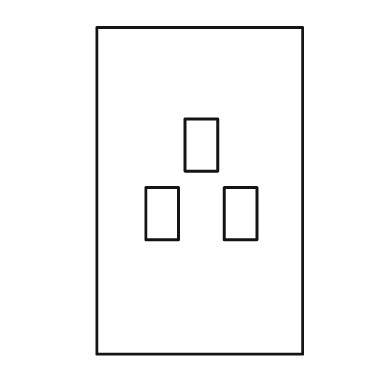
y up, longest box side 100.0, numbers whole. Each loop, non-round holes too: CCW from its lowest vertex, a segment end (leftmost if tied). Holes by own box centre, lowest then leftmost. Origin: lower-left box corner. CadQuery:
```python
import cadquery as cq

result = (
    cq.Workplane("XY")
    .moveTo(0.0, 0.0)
    .lineTo(63.0, 0.0)
    .lineTo(63.0, 100.0)
    .lineTo(0.0, 100.0)
    .close()
    .moveTo(15.0, 35.0)
    .lineTo(25.0, 35.0)
    .lineTo(25.0, 51.0)
    .lineTo(15.0, 51.0)
    .close()
    .moveTo(39.0, 35.0)
    .lineTo(49.0, 35.0)
    .lineTo(49.0, 51.0)
    .lineTo(39.0, 51.0)
    .close()
    .moveTo(27.0, 56.0)
    .lineTo(37.0, 56.0)
    .lineTo(37.0, 72.0)
    .lineTo(27.0, 72.0)
    .close()
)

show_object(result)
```